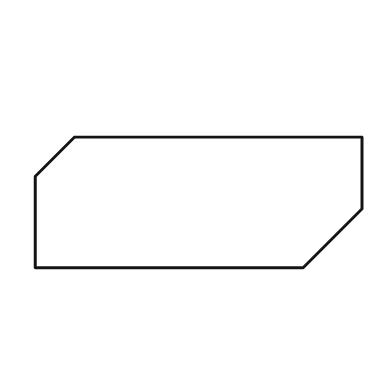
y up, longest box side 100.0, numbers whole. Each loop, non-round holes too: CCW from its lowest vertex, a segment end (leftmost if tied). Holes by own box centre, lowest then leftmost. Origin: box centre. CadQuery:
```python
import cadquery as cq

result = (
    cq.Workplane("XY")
    .moveTo(-50.0, -20.0)
    .lineTo(32.0, -20.0)
    .lineTo(50.0, -2.0)
    .lineTo(50.0, 20.0)
    .lineTo(-38.0, 20.0)
    .lineTo(-50.0, 8.0)
    .close()
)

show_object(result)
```